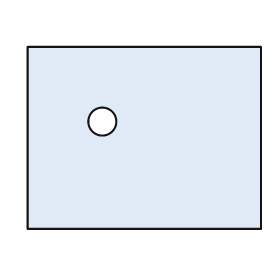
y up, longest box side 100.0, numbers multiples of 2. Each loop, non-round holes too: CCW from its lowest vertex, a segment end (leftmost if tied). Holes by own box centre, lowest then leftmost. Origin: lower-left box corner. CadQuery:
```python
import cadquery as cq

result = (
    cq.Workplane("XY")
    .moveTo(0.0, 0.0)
    .lineTo(100.0, 0.0)
    .lineTo(100.0, 78.0)
    .lineTo(0.0, 78.0)
    .close()
    .moveTo(32.0, 46.0)
    .circle(6.0)
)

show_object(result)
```